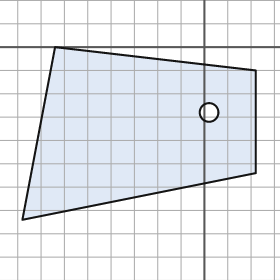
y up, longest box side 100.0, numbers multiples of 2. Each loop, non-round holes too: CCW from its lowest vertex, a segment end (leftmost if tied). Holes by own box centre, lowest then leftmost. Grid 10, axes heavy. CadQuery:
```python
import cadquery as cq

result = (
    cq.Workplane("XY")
    .moveTo(-78.0, -74.0)
    .lineTo(22.0, -54.0)
    .lineTo(22.0, -10.0)
    .lineTo(-64.0, 0.0)
    .close()
    .moveTo(2.0, -28.0)
    .circle(4.0)
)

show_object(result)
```